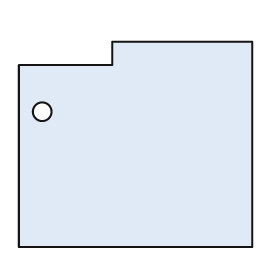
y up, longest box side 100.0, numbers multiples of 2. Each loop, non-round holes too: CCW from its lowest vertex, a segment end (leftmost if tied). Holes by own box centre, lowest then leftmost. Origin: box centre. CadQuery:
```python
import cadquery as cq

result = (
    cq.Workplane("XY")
    .moveTo(-50.0, -44.0)
    .lineTo(50.0, -44.0)
    .lineTo(50.0, 44.0)
    .lineTo(-10.0, 44.0)
    .lineTo(-10.0, 34.0)
    .lineTo(-50.0, 34.0)
    .close()
    .moveTo(-40.0, 14.0)
    .circle(4.0)
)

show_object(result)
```